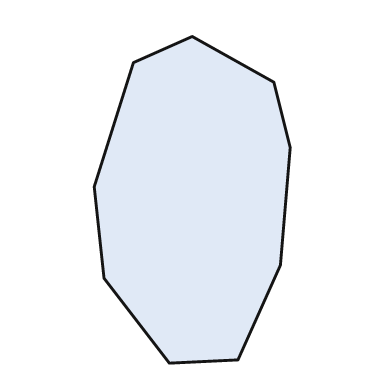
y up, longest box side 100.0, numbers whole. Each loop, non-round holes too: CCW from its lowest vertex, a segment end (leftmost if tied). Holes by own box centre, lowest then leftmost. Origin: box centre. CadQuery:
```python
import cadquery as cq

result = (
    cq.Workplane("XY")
    .moveTo(-7.0, -50.0)
    .lineTo(14.0, -49.0)
    .lineTo(27.0, -20.0)
    .lineTo(30.0, 16.0)
    .lineTo(25.0, 36.0)
    .lineTo(0.0, 50.0)
    .lineTo(-18.0, 42.0)
    .lineTo(-30.0, 4.0)
    .lineTo(-27.0, -24.0)
    .close()
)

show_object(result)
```